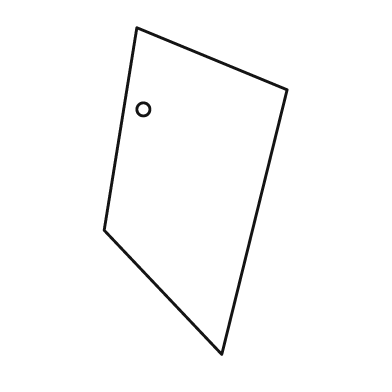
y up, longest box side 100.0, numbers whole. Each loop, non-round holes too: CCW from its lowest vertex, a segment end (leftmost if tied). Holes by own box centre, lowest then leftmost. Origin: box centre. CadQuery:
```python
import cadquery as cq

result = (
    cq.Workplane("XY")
    .moveTo(8.0, -50.0)
    .lineTo(28.0, 31.0)
    .lineTo(-18.0, 50.0)
    .lineTo(-28.0, -12.0)
    .close()
    .moveTo(-16.0, 25.0)
    .circle(2.0)
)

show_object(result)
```